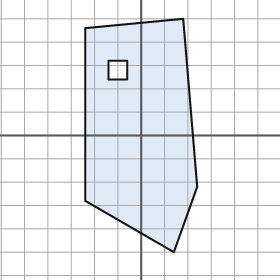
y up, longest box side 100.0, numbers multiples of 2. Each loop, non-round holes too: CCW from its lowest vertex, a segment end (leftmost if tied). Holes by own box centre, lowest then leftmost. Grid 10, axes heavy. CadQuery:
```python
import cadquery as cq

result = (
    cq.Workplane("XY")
    .moveTo(14.0, -50.0)
    .lineTo(24.0, -22.0)
    .lineTo(18.0, 50.0)
    .lineTo(-24.0, 46.0)
    .lineTo(-24.0, -28.0)
    .close()
    .moveTo(-14.0, 24.0)
    .lineTo(-6.0, 24.0)
    .lineTo(-6.0, 32.0)
    .lineTo(-14.0, 32.0)
    .close()
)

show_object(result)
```